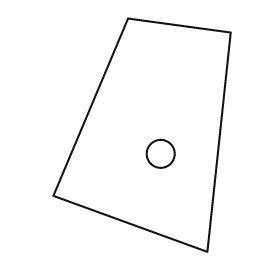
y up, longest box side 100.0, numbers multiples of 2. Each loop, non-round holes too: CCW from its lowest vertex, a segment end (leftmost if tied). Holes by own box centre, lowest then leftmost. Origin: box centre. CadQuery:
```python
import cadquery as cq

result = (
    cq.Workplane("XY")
    .moveTo(28.0, -50.0)
    .lineTo(38.0, 44.0)
    .lineTo(-6.0, 50.0)
    .lineTo(-38.0, -26.0)
    .close()
    .moveTo(8.0, -8.0)
    .circle(6.0)
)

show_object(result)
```